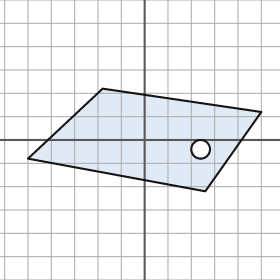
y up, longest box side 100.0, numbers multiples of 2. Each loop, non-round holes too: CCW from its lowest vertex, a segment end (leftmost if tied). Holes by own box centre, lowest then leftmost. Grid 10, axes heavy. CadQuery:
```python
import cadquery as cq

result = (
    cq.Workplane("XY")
    .moveTo(26.0, -22.0)
    .lineTo(50.0, 12.0)
    .lineTo(-18.0, 22.0)
    .lineTo(-50.0, -8.0)
    .close()
    .moveTo(24.0, -4.0)
    .circle(4.0)
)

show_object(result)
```